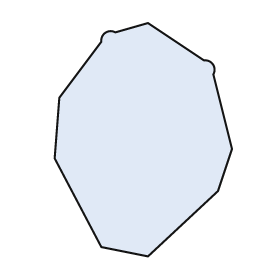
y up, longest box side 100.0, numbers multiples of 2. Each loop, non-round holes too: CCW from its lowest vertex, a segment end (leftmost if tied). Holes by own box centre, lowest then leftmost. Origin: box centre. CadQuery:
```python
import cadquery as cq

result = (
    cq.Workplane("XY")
    .moveTo(2.0, -50.0)
    .lineTo(32.0, -22.0)
    .lineTo(38.0, -4.0)
    .lineTo(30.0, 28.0)
    .threePointArc((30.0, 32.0), (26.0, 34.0))
    .lineTo(2.0, 50.0)
    .lineTo(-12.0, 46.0)
    .threePointArc((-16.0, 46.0), (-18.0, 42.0))
    .lineTo(-36.0, 18.0)
    .lineTo(-38.0, -8.0)
    .lineTo(-18.0, -46.0)
    .close()
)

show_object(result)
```